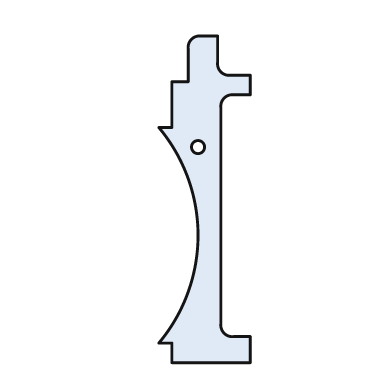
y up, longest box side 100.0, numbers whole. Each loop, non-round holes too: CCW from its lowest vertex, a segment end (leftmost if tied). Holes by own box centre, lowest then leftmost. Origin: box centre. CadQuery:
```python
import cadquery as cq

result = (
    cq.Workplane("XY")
    .moveTo(-10.0, -50.0)
    .lineTo(14.0, -50.0)
    .lineTo(14.0, -42.0)
    .lineTo(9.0, -42.0)
    .threePointArc((6.0, -41.0), (5.0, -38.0))
    .lineTo(5.0, 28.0)
    .threePointArc((6.0, 31.0), (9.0, 32.0))
    .lineTo(14.0, 32.0)
    .lineTo(14.0, 38.0)
    .lineTo(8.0, 38.0)
    .threePointArc((5.0, 39.0), (4.0, 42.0))
    .lineTo(4.0, 50.0)
    .lineTo(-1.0, 50.0)
    .threePointArc((-4.0, 49.0), (-5.0, 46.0))
    .lineTo(-5.0, 36.0)
    .lineTo(-10.0, 36.0)
    .lineTo(-10.0, 22.0)
    .lineTo(-14.0, 22.0)
    .threePointArc((-2.0, -11.0), (-14.0, -44.0))
    .lineTo(-10.0, -44.0)
    .close()
    .moveTo(-2.0, 16.0)
    .circle(2.0)
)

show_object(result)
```